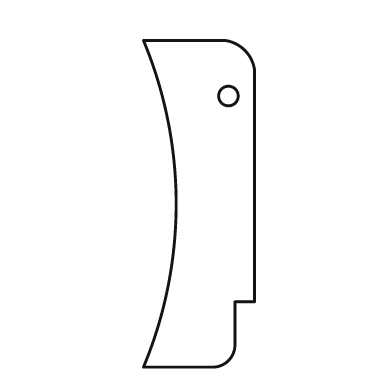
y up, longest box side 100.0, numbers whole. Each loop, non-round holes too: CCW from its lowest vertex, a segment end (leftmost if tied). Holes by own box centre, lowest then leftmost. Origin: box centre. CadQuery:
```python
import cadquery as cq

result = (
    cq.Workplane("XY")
    .moveTo(-17.0, -50.0)
    .lineTo(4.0, -50.0)
    .threePointArc((9.0, -48.0), (11.0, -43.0))
    .lineTo(11.0, -30.0)
    .lineTo(17.0, -30.0)
    .lineTo(17.0, 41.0)
    .threePointArc((14.0, 47.0), (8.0, 50.0))
    .lineTo(-17.0, 50.0)
    .threePointArc((-7.0, 0.0), (-17.0, -50.0))
    .close()
    .moveTo(9.0, 33.0)
    .circle(3.0)
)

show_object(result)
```